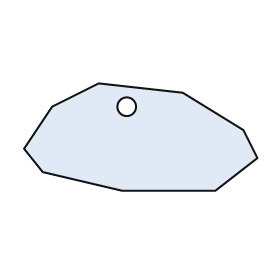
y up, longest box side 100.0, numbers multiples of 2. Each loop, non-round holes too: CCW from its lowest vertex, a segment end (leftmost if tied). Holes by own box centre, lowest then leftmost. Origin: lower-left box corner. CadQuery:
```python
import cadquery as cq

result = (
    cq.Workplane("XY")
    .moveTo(42.0, 0.0)
    .lineTo(82.0, 0.0)
    .lineTo(100.0, 14.0)
    .lineTo(94.0, 26.0)
    .lineTo(68.0, 42.0)
    .lineTo(32.0, 46.0)
    .lineTo(12.0, 36.0)
    .lineTo(0.0, 18.0)
    .lineTo(8.0, 8.0)
    .close()
    .moveTo(44.0, 36.0)
    .circle(4.0)
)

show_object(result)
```